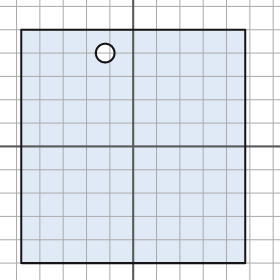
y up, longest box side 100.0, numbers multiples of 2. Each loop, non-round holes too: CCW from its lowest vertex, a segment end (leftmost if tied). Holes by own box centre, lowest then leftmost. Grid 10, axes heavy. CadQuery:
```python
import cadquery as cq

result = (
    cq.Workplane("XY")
    .moveTo(-48.0, -50.0)
    .lineTo(48.0, -50.0)
    .lineTo(48.0, 50.0)
    .lineTo(-48.0, 50.0)
    .close()
    .moveTo(-12.0, 40.0)
    .circle(4.0)
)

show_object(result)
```